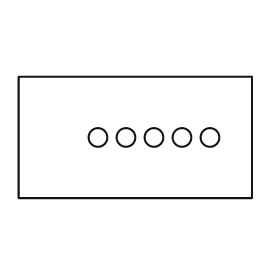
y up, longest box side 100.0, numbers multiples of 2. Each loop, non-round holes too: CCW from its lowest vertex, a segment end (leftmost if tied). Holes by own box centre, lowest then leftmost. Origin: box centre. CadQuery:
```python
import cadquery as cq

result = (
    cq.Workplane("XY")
    .moveTo(-50.0, -26.0)
    .lineTo(50.0, -26.0)
    .lineTo(50.0, 26.0)
    .lineTo(-50.0, 26.0)
    .close()
    .moveTo(-16.0, 0.0)
    .circle(4.0)
    .moveTo(-4.0, 0.0)
    .circle(4.0)
    .moveTo(8.0, 0.0)
    .circle(4.0)
    .moveTo(20.0, 0.0)
    .circle(4.0)
    .moveTo(32.0, 0.0)
    .circle(4.0)
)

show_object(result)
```